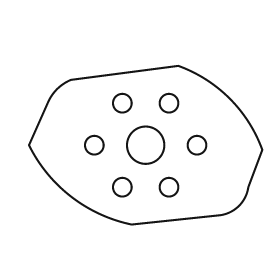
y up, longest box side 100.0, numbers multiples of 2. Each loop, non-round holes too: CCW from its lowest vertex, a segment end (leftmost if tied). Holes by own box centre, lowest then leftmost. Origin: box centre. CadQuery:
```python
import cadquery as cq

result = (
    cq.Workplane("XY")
    .moveTo(-6.0, -34.0)
    .lineTo(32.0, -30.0)
    .threePointArc((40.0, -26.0), (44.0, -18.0))
    .lineTo(50.0, -2.0)
    .threePointArc((36.0, 20.0), (14.0, 34.0))
    .lineTo(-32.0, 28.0)
    .threePointArc((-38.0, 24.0), (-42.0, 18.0))
    .lineTo(-50.0, 0.0)
    .threePointArc((-32.0, -22.0), (-6.0, -34.0))
    .close()
    .moveTo(-10.0, -18.0)
    .circle(4.0)
    .moveTo(10.0, -18.0)
    .circle(4.0)
    .moveTo(-22.0, 0.0)
    .circle(4.0)
    .moveTo(0.0, 0.0)
    .circle(8.0)
    .moveTo(22.0, 0.0)
    .circle(4.0)
    .moveTo(-10.0, 18.0)
    .circle(4.0)
    .moveTo(10.0, 18.0)
    .circle(4.0)
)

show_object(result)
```